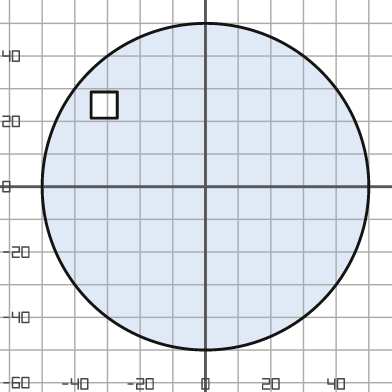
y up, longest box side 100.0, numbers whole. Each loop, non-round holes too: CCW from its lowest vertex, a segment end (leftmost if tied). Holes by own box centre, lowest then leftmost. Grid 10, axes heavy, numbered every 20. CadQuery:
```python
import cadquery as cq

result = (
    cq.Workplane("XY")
    .moveTo(0.0, 0.0)
    .circle(50.0)
    .moveTo(-35.0, 21.0)
    .lineTo(-27.0, 21.0)
    .lineTo(-27.0, 29.0)
    .lineTo(-35.0, 29.0)
    .close()
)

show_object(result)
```